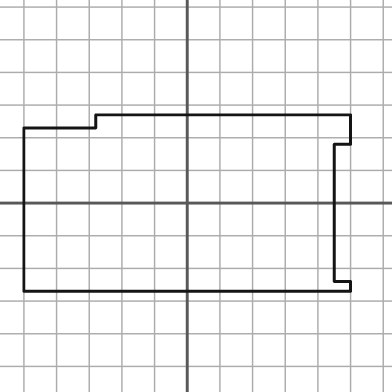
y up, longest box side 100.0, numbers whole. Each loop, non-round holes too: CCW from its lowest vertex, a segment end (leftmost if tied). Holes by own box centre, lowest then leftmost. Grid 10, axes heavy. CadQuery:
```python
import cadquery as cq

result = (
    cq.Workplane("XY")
    .moveTo(-50.0, -27.0)
    .lineTo(50.0, -27.0)
    .lineTo(50.0, -24.0)
    .lineTo(45.0, -24.0)
    .lineTo(45.0, 18.0)
    .lineTo(50.0, 18.0)
    .lineTo(50.0, 27.0)
    .lineTo(-28.0, 27.0)
    .lineTo(-28.0, 23.0)
    .lineTo(-50.0, 23.0)
    .close()
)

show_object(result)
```